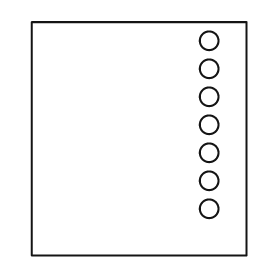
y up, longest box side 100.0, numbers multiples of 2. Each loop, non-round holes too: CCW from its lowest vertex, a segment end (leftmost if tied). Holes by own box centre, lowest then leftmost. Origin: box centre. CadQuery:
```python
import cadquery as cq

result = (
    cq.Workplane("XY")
    .moveTo(-46.0, -50.0)
    .lineTo(46.0, -50.0)
    .lineTo(46.0, 50.0)
    .lineTo(-46.0, 50.0)
    .close()
    .moveTo(30.0, -30.0)
    .circle(4.0)
    .moveTo(30.0, -18.0)
    .circle(4.0)
    .moveTo(30.0, -6.0)
    .circle(4.0)
    .moveTo(30.0, 6.0)
    .circle(4.0)
    .moveTo(30.0, 18.0)
    .circle(4.0)
    .moveTo(30.0, 30.0)
    .circle(4.0)
    .moveTo(30.0, 42.0)
    .circle(4.0)
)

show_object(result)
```